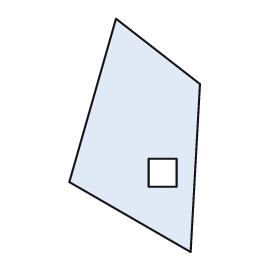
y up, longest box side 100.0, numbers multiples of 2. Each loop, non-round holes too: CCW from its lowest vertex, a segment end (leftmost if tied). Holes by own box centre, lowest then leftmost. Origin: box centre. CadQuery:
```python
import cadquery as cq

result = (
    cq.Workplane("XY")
    .moveTo(24.0, -50.0)
    .lineTo(28.0, 22.0)
    .lineTo(-8.0, 50.0)
    .lineTo(-28.0, -20.0)
    .close()
    .moveTo(6.0, -22.0)
    .lineTo(18.0, -22.0)
    .lineTo(18.0, -10.0)
    .lineTo(6.0, -10.0)
    .close()
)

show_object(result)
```